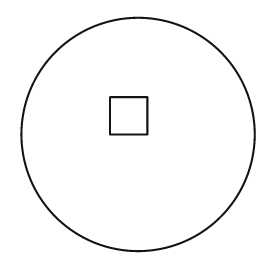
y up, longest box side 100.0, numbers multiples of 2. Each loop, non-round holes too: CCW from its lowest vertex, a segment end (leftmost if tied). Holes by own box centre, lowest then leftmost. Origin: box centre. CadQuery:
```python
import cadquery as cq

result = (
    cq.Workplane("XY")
    .moveTo(0.0, 0.0)
    .circle(50.0)
    .moveTo(-12.0, 0.0)
    .lineTo(4.0, 0.0)
    .lineTo(4.0, 16.0)
    .lineTo(-12.0, 16.0)
    .close()
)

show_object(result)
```